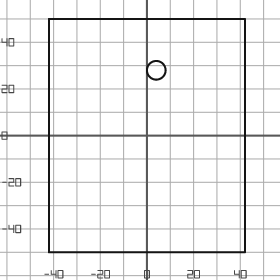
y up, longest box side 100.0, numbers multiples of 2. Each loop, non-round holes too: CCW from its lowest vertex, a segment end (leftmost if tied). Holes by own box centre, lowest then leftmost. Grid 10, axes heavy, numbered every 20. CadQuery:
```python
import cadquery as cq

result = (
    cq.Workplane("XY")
    .moveTo(-42.0, -50.0)
    .lineTo(42.0, -50.0)
    .lineTo(42.0, 50.0)
    .lineTo(-42.0, 50.0)
    .close()
    .moveTo(4.0, 28.0)
    .circle(4.0)
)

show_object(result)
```